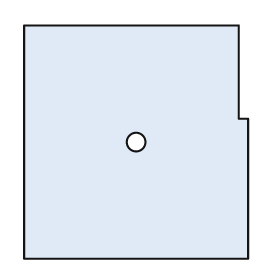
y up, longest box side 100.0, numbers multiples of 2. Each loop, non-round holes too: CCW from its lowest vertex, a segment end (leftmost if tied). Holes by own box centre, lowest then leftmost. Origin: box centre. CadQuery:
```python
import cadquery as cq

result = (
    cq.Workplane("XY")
    .moveTo(-48.0, -50.0)
    .lineTo(48.0, -50.0)
    .lineTo(48.0, 10.0)
    .lineTo(44.0, 10.0)
    .lineTo(44.0, 50.0)
    .lineTo(-48.0, 50.0)
    .close()
    .moveTo(0.0, 0.0)
    .circle(4.0)
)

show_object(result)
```